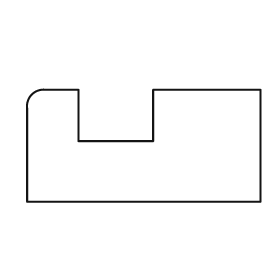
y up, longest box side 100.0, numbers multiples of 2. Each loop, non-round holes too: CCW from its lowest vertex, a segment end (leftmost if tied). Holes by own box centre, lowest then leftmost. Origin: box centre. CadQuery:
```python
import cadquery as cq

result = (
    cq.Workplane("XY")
    .moveTo(-50.0, -24.0)
    .lineTo(50.0, -24.0)
    .lineTo(50.0, 24.0)
    .lineTo(4.0, 24.0)
    .lineTo(4.0, 2.0)
    .lineTo(-28.0, 2.0)
    .lineTo(-28.0, 24.0)
    .lineTo(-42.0, 24.0)
    .threePointArc((-48.0, 22.0), (-50.0, 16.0))
    .close()
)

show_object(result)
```